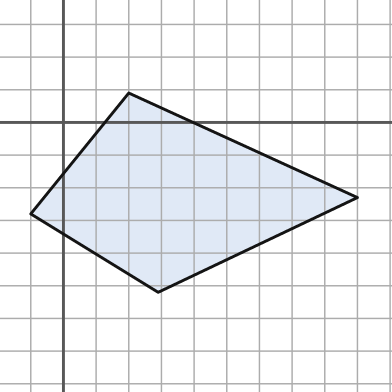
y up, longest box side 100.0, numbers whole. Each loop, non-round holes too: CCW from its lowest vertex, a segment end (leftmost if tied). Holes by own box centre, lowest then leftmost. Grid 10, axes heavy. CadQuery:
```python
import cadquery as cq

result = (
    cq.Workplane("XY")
    .moveTo(29.0, -52.0)
    .lineTo(90.0, -23.0)
    .lineTo(20.0, 9.0)
    .lineTo(-10.0, -28.0)
    .close()
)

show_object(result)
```